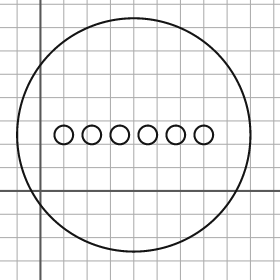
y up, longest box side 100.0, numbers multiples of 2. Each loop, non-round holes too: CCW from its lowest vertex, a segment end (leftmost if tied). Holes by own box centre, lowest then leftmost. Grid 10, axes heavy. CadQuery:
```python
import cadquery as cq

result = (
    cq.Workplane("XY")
    .moveTo(40.0, 24.0)
    .circle(50.0)
    .moveTo(10.0, 24.0)
    .circle(4.0)
    .moveTo(22.0, 24.0)
    .circle(4.0)
    .moveTo(34.0, 24.0)
    .circle(4.0)
    .moveTo(46.0, 24.0)
    .circle(4.0)
    .moveTo(58.0, 24.0)
    .circle(4.0)
    .moveTo(70.0, 24.0)
    .circle(4.0)
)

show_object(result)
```